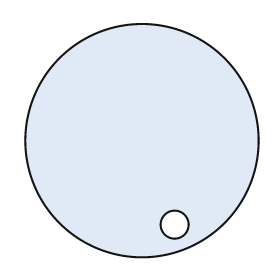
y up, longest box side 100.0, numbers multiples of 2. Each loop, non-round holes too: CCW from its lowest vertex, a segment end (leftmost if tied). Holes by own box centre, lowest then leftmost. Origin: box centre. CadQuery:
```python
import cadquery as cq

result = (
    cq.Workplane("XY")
    .moveTo(0.0, 0.0)
    .circle(50.0)
    .moveTo(14.0, -36.0)
    .circle(6.0)
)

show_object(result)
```